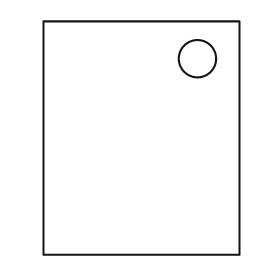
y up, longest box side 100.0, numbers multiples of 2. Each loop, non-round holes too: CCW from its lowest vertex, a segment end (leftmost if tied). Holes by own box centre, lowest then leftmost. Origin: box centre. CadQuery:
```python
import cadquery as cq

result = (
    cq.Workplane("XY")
    .moveTo(-42.0, -50.0)
    .lineTo(42.0, -50.0)
    .lineTo(42.0, 50.0)
    .lineTo(-42.0, 50.0)
    .close()
    .moveTo(24.0, 34.0)
    .circle(8.0)
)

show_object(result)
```